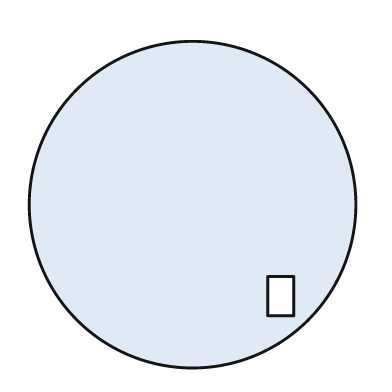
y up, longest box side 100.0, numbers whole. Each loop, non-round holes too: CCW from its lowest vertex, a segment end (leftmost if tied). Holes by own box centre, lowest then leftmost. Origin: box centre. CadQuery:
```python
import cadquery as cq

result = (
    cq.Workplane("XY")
    .moveTo(0.0, 0.0)
    .circle(50.0)
    .moveTo(23.0, -34.0)
    .lineTo(31.0, -34.0)
    .lineTo(31.0, -22.0)
    .lineTo(23.0, -22.0)
    .close()
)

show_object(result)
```